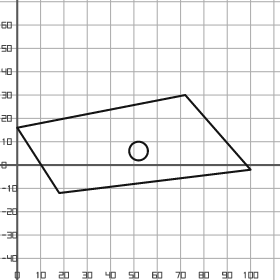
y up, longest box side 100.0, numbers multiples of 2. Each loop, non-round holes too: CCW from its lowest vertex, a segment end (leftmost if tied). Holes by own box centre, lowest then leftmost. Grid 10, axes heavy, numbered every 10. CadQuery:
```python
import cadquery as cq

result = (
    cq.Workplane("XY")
    .moveTo(18.0, -12.0)
    .lineTo(100.0, -2.0)
    .lineTo(72.0, 30.0)
    .lineTo(0.0, 16.0)
    .close()
    .moveTo(52.0, 6.0)
    .circle(4.0)
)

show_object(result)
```